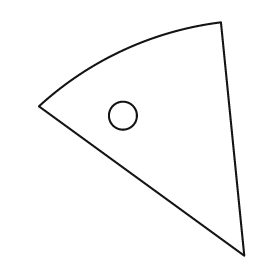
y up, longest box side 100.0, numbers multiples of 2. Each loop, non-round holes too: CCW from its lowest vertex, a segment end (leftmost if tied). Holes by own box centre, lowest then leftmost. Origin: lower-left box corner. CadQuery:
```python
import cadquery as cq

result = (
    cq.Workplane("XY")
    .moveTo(88.0, 0.0)
    .lineTo(78.0, 100.0)
    .threePointArc((36.0, 88.0), (0.0, 64.0))
    .close()
    .moveTo(36.0, 60.0)
    .circle(6.0)
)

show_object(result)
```